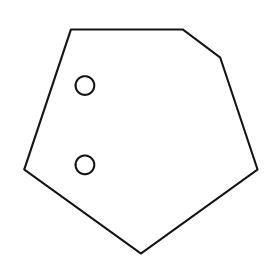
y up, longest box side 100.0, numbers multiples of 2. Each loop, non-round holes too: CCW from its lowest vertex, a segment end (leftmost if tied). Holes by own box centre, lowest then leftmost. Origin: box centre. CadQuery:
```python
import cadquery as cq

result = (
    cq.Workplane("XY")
    .moveTo(0.0, -48.0)
    .lineTo(50.0, -12.0)
    .lineTo(34.0, 36.0)
    .lineTo(18.0, 48.0)
    .lineTo(-30.0, 48.0)
    .lineTo(-50.0, -12.0)
    .close()
    .moveTo(-24.0, -10.0)
    .circle(4.0)
    .moveTo(-24.0, 24.0)
    .circle(4.0)
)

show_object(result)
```